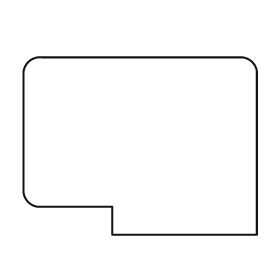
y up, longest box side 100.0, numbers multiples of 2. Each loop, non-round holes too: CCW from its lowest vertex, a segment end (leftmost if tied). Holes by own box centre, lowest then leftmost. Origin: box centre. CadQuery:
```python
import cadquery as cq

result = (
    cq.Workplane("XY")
    .moveTo(-12.0, -38.0)
    .lineTo(50.0, -38.0)
    .lineTo(50.0, 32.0)
    .threePointArc((48.0, 36.0), (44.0, 38.0))
    .lineTo(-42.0, 38.0)
    .threePointArc((-48.0, 36.0), (-50.0, 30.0))
    .lineTo(-50.0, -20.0)
    .threePointArc((-48.0, -24.0), (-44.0, -26.0))
    .lineTo(-12.0, -26.0)
    .close()
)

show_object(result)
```